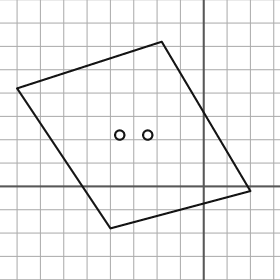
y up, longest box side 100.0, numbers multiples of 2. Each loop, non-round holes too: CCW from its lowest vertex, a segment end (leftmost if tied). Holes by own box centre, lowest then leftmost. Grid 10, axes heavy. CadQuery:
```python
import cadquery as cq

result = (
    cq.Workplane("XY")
    .moveTo(-40.0, -18.0)
    .lineTo(20.0, -2.0)
    .lineTo(-18.0, 62.0)
    .lineTo(-80.0, 42.0)
    .close()
    .moveTo(-36.0, 22.0)
    .circle(2.0)
    .moveTo(-24.0, 22.0)
    .circle(2.0)
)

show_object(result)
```